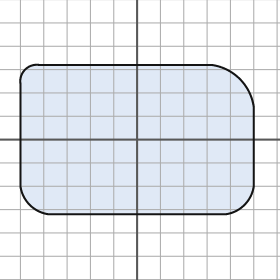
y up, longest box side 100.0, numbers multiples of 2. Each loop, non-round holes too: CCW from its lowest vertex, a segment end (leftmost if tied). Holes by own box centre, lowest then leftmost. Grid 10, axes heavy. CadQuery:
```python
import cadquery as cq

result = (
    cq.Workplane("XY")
    .moveTo(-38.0, -32.0)
    .lineTo(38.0, -32.0)
    .threePointArc((46.0, -28.0), (50.0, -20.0))
    .lineTo(50.0, 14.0)
    .threePointArc((44.0, 26.0), (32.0, 32.0))
    .lineTo(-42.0, 32.0)
    .threePointArc((-48.0, 30.0), (-50.0, 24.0))
    .lineTo(-50.0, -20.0)
    .threePointArc((-46.0, -28.0), (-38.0, -32.0))
    .close()
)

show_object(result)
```